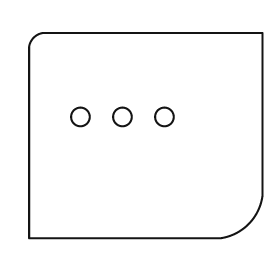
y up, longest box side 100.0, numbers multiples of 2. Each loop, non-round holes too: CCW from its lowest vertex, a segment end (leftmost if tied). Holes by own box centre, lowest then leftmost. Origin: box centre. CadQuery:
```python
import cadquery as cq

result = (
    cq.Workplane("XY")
    .moveTo(-50.0, -44.0)
    .lineTo(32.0, -44.0)
    .threePointArc((44.0, -38.0), (50.0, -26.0))
    .lineTo(50.0, 44.0)
    .lineTo(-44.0, 44.0)
    .threePointArc((-48.0, 42.0), (-50.0, 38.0))
    .close()
    .moveTo(-28.0, 8.0)
    .circle(4.0)
    .moveTo(-10.0, 8.0)
    .circle(4.0)
    .moveTo(8.0, 8.0)
    .circle(4.0)
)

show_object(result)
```